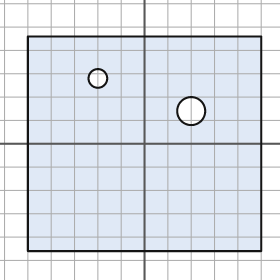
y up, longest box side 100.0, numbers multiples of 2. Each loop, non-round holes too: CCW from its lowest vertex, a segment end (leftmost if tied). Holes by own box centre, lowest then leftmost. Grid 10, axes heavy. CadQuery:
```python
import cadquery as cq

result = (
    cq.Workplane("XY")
    .moveTo(-50.0, -46.0)
    .lineTo(50.0, -46.0)
    .lineTo(50.0, 46.0)
    .lineTo(-50.0, 46.0)
    .close()
    .moveTo(20.0, 14.0)
    .circle(6.0)
    .moveTo(-20.0, 28.0)
    .circle(4.0)
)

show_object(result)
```